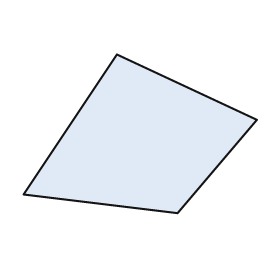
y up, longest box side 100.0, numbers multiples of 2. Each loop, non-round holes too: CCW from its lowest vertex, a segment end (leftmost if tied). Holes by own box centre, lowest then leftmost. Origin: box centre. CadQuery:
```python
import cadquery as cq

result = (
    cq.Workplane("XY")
    .moveTo(16.0, -34.0)
    .lineTo(50.0, 6.0)
    .lineTo(-10.0, 34.0)
    .lineTo(-50.0, -26.0)
    .close()
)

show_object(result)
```